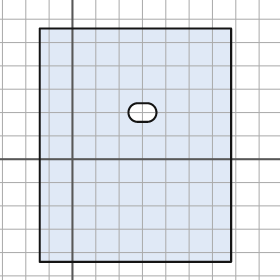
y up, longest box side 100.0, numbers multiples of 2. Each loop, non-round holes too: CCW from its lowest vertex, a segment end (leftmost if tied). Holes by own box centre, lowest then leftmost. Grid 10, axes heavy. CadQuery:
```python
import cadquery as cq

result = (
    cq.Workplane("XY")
    .moveTo(-14.0, -44.0)
    .lineTo(68.0, -44.0)
    .lineTo(68.0, 56.0)
    .lineTo(-14.0, 56.0)
    .close()
    .moveTo(28.0, 16.0)
    .lineTo(32.0, 16.0)
    .threePointArc((36.0, 20.0), (32.0, 24.0))
    .lineTo(28.0, 24.0)
    .threePointArc((24.0, 20.0), (28.0, 16.0))
    .close()
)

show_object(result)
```